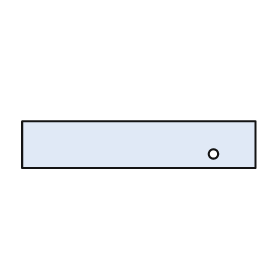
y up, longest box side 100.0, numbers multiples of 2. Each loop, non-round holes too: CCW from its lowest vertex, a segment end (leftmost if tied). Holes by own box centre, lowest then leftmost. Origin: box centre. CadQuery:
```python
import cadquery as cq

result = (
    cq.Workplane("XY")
    .moveTo(-50.0, -10.0)
    .lineTo(50.0, -10.0)
    .lineTo(50.0, 10.0)
    .lineTo(-50.0, 10.0)
    .close()
    .moveTo(32.0, -4.0)
    .circle(2.0)
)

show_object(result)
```